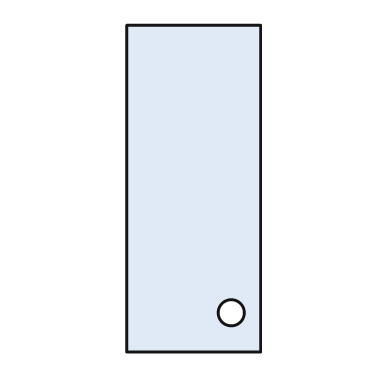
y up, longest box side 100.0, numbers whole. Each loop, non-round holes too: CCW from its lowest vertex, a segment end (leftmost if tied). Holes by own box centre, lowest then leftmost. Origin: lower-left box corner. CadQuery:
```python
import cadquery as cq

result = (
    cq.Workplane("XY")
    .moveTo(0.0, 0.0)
    .lineTo(41.0, 0.0)
    .lineTo(41.0, 100.0)
    .lineTo(0.0, 100.0)
    .close()
    .moveTo(32.0, 12.0)
    .circle(4.0)
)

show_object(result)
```